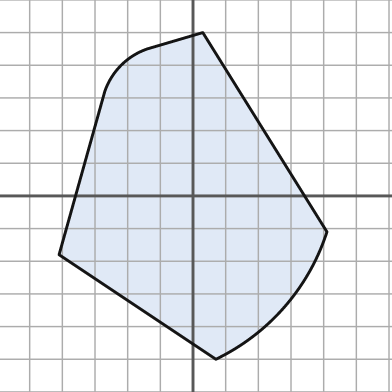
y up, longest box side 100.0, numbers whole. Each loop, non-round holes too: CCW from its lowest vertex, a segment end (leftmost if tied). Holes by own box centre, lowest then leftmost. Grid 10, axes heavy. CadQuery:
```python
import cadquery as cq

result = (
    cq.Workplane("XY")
    .moveTo(7.0, -50.0)
    .threePointArc((28.0, -34.0), (41.0, -11.0))
    .lineTo(3.0, 50.0)
    .lineTo(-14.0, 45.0)
    .threePointArc((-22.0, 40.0), (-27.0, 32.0))
    .lineTo(-41.0, -18.0)
    .close()
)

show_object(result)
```